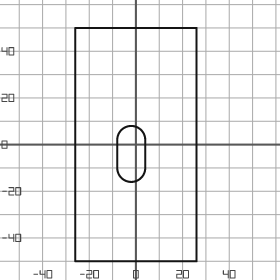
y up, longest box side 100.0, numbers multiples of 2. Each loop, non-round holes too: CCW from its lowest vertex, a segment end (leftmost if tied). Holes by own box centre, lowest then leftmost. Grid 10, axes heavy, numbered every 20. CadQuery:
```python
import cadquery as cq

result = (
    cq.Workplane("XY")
    .moveTo(-26.0, -50.0)
    .lineTo(26.0, -50.0)
    .lineTo(26.0, 50.0)
    .lineTo(-26.0, 50.0)
    .close()
    .moveTo(-8.0, -10.0)
    .threePointArc((-2.0, -16.0), (4.0, -10.0))
    .lineTo(4.0, 2.0)
    .threePointArc((-2.0, 8.0), (-8.0, 2.0))
    .close()
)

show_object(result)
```